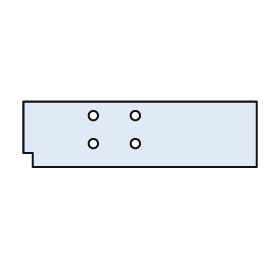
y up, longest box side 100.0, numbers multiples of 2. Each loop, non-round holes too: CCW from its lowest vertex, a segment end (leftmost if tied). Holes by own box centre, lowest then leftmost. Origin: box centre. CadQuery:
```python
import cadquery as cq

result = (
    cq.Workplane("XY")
    .moveTo(-46.0, -14.0)
    .lineTo(50.0, -14.0)
    .lineTo(50.0, 14.0)
    .lineTo(-50.0, 14.0)
    .lineTo(-50.0, -8.0)
    .lineTo(-46.0, -8.0)
    .close()
    .moveTo(-20.0, -4.0)
    .circle(2.0)
    .moveTo(-2.0, -4.0)
    .circle(2.0)
    .moveTo(-20.0, 8.0)
    .circle(2.0)
    .moveTo(-2.0, 8.0)
    .circle(2.0)
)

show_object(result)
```